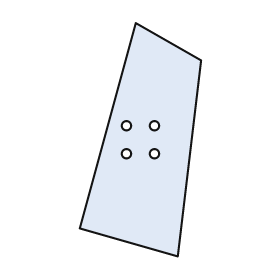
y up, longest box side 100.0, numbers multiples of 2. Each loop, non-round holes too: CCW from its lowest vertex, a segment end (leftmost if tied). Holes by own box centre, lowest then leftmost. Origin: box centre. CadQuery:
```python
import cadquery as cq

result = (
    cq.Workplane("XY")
    .moveTo(16.0, -50.0)
    .lineTo(26.0, 34.0)
    .lineTo(-2.0, 50.0)
    .lineTo(-26.0, -38.0)
    .close()
    .moveTo(-6.0, -6.0)
    .circle(2.0)
    .moveTo(6.0, -6.0)
    .circle(2.0)
    .moveTo(-6.0, 6.0)
    .circle(2.0)
    .moveTo(6.0, 6.0)
    .circle(2.0)
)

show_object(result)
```